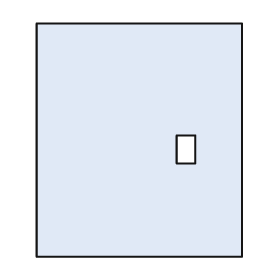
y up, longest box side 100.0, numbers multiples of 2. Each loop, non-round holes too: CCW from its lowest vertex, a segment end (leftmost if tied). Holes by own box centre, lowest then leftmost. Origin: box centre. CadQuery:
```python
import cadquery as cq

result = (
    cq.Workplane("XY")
    .moveTo(-44.0, -50.0)
    .lineTo(44.0, -50.0)
    .lineTo(44.0, 50.0)
    .lineTo(-44.0, 50.0)
    .close()
    .moveTo(16.0, -10.0)
    .lineTo(24.0, -10.0)
    .lineTo(24.0, 2.0)
    .lineTo(16.0, 2.0)
    .close()
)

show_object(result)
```